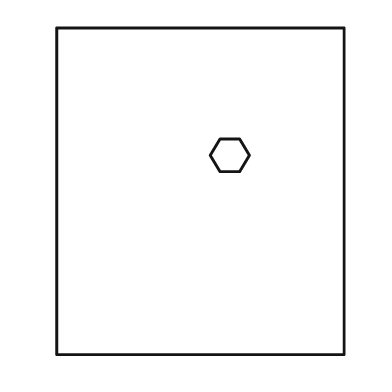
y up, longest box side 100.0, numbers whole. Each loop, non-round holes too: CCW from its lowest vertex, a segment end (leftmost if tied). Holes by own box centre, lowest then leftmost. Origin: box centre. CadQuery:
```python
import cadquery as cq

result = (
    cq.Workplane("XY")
    .moveTo(-44.0, -50.0)
    .lineTo(44.0, -50.0)
    .lineTo(44.0, 50.0)
    .lineTo(-44.0, 50.0)
    .close()
    .moveTo(6.0, 6.0)
    .lineTo(12.0, 6.0)
    .lineTo(15.0, 11.0)
    .lineTo(12.0, 16.0)
    .lineTo(6.0, 16.0)
    .lineTo(3.0, 11.0)
    .close()
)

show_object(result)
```